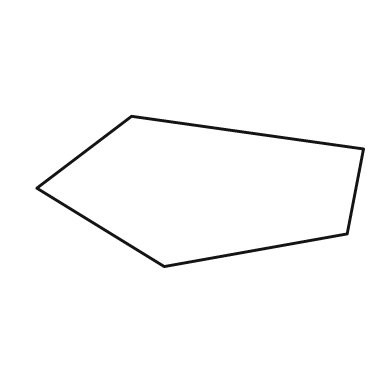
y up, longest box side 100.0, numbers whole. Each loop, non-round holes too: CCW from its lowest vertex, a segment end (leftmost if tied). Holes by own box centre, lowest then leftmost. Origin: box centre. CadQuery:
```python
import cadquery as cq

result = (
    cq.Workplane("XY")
    .moveTo(-11.0, -23.0)
    .lineTo(45.0, -13.0)
    .lineTo(50.0, 13.0)
    .lineTo(-21.0, 23.0)
    .lineTo(-50.0, 1.0)
    .close()
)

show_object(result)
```